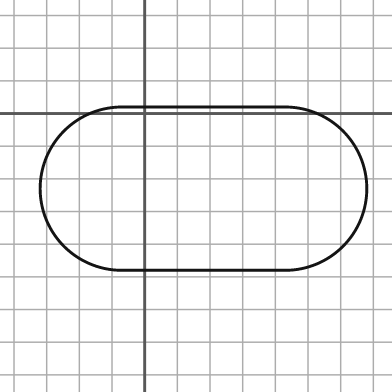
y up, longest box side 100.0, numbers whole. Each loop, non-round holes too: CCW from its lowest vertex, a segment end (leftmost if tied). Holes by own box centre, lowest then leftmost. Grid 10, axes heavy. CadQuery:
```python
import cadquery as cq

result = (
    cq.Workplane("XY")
    .moveTo(-7.0, -48.0)
    .lineTo(43.0, -48.0)
    .threePointArc((68.0, -23.0), (43.0, 2.0))
    .lineTo(-7.0, 2.0)
    .threePointArc((-32.0, -23.0), (-7.0, -48.0))
    .close()
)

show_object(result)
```